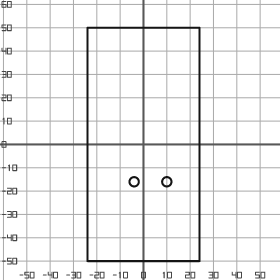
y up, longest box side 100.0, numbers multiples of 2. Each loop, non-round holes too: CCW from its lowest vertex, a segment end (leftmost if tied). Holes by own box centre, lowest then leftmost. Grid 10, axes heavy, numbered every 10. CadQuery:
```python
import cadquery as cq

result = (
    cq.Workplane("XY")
    .moveTo(-24.0, -50.0)
    .lineTo(24.0, -50.0)
    .lineTo(24.0, 50.0)
    .lineTo(-24.0, 50.0)
    .close()
    .moveTo(-4.0, -16.0)
    .circle(2.0)
    .moveTo(10.0, -16.0)
    .circle(2.0)
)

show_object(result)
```